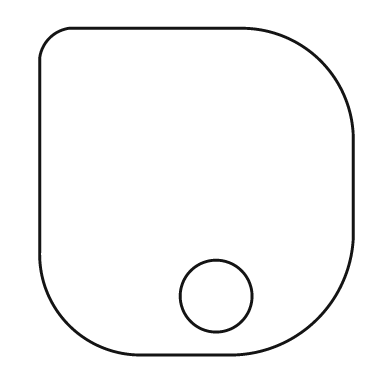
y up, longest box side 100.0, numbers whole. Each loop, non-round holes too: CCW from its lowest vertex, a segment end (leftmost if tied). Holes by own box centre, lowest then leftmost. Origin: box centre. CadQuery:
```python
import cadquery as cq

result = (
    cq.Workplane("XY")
    .moveTo(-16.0, -50.0)
    .lineTo(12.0, -50.0)
    .threePointArc((37.0, -39.0), (48.0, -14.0))
    .lineTo(48.0, 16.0)
    .threePointArc((38.0, 40.0), (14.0, 50.0))
    .lineTo(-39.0, 50.0)
    .threePointArc((-45.0, 47.0), (-48.0, 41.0))
    .lineTo(-48.0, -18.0)
    .threePointArc((-39.0, -41.0), (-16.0, -50.0))
    .close()
    .moveTo(6.0, -32.0)
    .circle(11.0)
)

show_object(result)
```